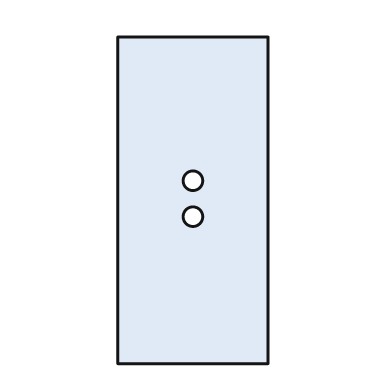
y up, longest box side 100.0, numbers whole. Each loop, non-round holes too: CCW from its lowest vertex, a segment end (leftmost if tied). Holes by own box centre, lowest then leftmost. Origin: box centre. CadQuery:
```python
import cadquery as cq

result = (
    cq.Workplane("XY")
    .moveTo(-23.0, -50.0)
    .lineTo(23.0, -50.0)
    .lineTo(23.0, 50.0)
    .lineTo(-23.0, 50.0)
    .close()
    .moveTo(0.0, -5.0)
    .circle(3.0)
    .moveTo(0.0, 6.0)
    .circle(3.0)
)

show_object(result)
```